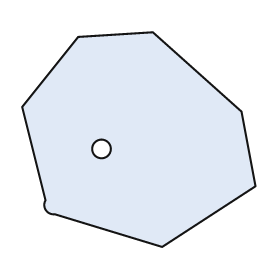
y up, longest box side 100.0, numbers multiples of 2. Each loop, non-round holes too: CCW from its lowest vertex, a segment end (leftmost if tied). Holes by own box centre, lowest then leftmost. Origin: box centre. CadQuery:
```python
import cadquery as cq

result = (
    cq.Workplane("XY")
    .moveTo(10.0, -46.0)
    .lineTo(50.0, -20.0)
    .lineTo(44.0, 12.0)
    .lineTo(6.0, 46.0)
    .lineTo(-26.0, 44.0)
    .lineTo(-50.0, 14.0)
    .lineTo(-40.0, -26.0)
    .threePointArc((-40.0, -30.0), (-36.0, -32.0))
    .close()
    .moveTo(-16.0, -4.0)
    .circle(4.0)
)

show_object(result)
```